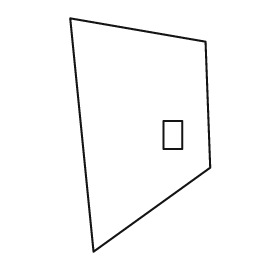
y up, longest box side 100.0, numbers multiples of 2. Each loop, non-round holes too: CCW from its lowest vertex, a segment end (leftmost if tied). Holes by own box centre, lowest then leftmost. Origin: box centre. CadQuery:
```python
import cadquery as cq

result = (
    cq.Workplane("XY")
    .moveTo(-20.0, -50.0)
    .lineTo(30.0, -14.0)
    .lineTo(28.0, 40.0)
    .lineTo(-30.0, 50.0)
    .close()
    .moveTo(10.0, -6.0)
    .lineTo(18.0, -6.0)
    .lineTo(18.0, 6.0)
    .lineTo(10.0, 6.0)
    .close()
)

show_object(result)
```